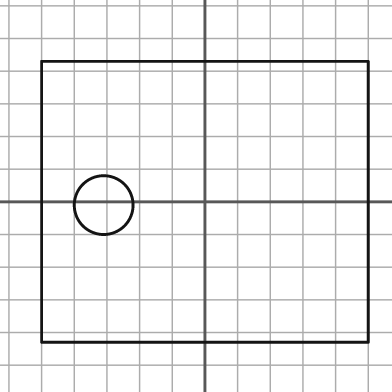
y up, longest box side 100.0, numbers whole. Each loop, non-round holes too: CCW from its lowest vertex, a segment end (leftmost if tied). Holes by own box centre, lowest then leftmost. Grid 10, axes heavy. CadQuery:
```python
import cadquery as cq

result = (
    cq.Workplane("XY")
    .moveTo(-50.0, -43.0)
    .lineTo(50.0, -43.0)
    .lineTo(50.0, 43.0)
    .lineTo(-50.0, 43.0)
    .close()
    .moveTo(-31.0, -1.0)
    .circle(9.0)
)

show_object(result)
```